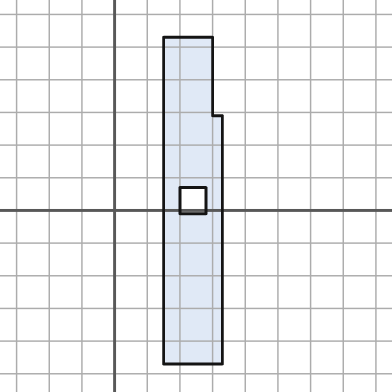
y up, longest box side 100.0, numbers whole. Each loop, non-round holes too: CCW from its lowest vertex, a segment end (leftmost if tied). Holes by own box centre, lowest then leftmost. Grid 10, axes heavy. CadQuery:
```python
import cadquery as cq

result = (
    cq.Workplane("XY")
    .moveTo(15.0, -47.0)
    .lineTo(33.0, -47.0)
    .lineTo(33.0, 29.0)
    .lineTo(30.0, 29.0)
    .lineTo(30.0, 53.0)
    .lineTo(15.0, 53.0)
    .close()
    .moveTo(20.0, -1.0)
    .lineTo(28.0, -1.0)
    .lineTo(28.0, 7.0)
    .lineTo(20.0, 7.0)
    .close()
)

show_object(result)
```